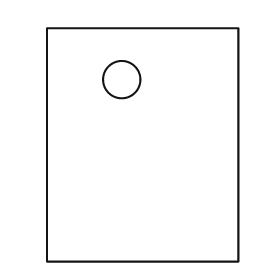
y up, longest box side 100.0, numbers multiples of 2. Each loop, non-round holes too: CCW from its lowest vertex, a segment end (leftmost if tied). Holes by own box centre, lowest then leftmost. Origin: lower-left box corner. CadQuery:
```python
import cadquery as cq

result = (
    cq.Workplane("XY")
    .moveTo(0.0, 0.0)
    .lineTo(82.0, 0.0)
    .lineTo(82.0, 100.0)
    .lineTo(0.0, 100.0)
    .close()
    .moveTo(32.0, 78.0)
    .circle(8.0)
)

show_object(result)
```